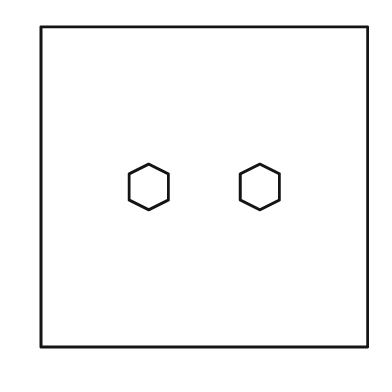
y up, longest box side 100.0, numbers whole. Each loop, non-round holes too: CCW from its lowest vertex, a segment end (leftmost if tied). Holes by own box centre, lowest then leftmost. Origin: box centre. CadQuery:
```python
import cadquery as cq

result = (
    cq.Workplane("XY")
    .moveTo(-50.0, -49.0)
    .lineTo(50.0, -49.0)
    .lineTo(50.0, 49.0)
    .lineTo(-50.0, 49.0)
    .close()
    .moveTo(-17.0, -7.0)
    .lineTo(-11.0, -4.0)
    .lineTo(-11.0, 4.0)
    .lineTo(-17.0, 7.0)
    .lineTo(-23.0, 4.0)
    .lineTo(-23.0, -4.0)
    .close()
    .moveTo(17.0, -7.0)
    .lineTo(23.0, -4.0)
    .lineTo(23.0, 4.0)
    .lineTo(17.0, 7.0)
    .lineTo(11.0, 4.0)
    .lineTo(11.0, -4.0)
    .close()
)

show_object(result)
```